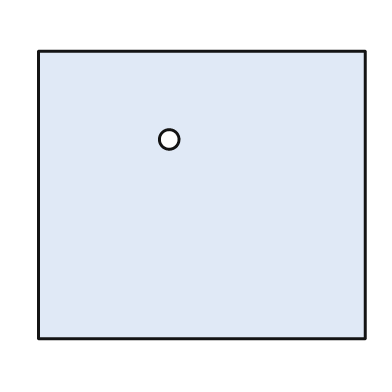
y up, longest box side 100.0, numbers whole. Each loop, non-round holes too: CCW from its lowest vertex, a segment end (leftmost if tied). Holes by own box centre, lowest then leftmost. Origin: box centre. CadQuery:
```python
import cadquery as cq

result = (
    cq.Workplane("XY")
    .moveTo(-50.0, -44.0)
    .lineTo(50.0, -44.0)
    .lineTo(50.0, 44.0)
    .lineTo(-50.0, 44.0)
    .close()
    .moveTo(-10.0, 17.0)
    .circle(3.0)
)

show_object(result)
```